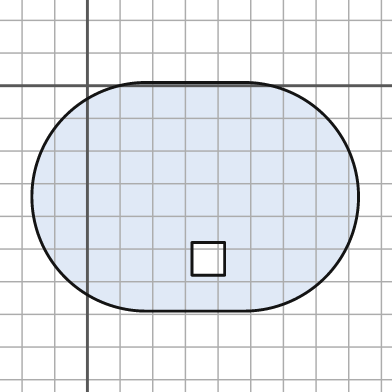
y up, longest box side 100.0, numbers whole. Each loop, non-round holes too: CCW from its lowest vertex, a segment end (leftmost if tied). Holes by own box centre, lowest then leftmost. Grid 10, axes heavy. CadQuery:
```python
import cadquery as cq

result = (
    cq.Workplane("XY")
    .moveTo(18.0, -69.0)
    .lineTo(48.0, -69.0)
    .threePointArc((83.0, -34.0), (48.0, 1.0))
    .lineTo(18.0, 1.0)
    .threePointArc((-17.0, -34.0), (18.0, -69.0))
    .close()
    .moveTo(32.0, -58.0)
    .lineTo(42.0, -58.0)
    .lineTo(42.0, -48.0)
    .lineTo(32.0, -48.0)
    .close()
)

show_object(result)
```